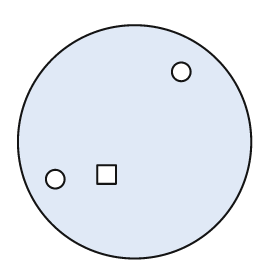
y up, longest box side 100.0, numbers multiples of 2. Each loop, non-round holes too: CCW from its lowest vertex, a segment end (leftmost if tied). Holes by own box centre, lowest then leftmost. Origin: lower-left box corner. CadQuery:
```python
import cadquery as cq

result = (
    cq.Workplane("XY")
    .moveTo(50.0, 50.0)
    .circle(50.0)
    .moveTo(16.0, 34.0)
    .circle(4.0)
    .moveTo(34.0, 32.0)
    .lineTo(42.0, 32.0)
    .lineTo(42.0, 40.0)
    .lineTo(34.0, 40.0)
    .close()
    .moveTo(70.0, 80.0)
    .circle(4.0)
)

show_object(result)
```